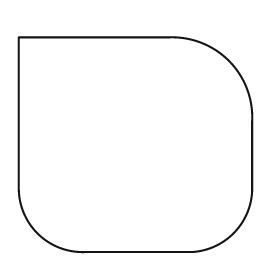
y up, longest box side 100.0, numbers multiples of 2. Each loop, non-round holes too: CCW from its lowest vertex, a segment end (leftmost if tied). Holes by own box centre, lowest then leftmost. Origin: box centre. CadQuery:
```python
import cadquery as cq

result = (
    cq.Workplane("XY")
    .moveTo(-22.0, -46.0)
    .lineTo(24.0, -46.0)
    .threePointArc((42.0, -38.0), (50.0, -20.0))
    .lineTo(50.0, 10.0)
    .threePointArc((40.0, 36.0), (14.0, 46.0))
    .lineTo(-50.0, 46.0)
    .lineTo(-50.0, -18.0)
    .threePointArc((-42.0, -38.0), (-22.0, -46.0))
    .close()
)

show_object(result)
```